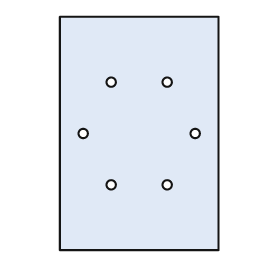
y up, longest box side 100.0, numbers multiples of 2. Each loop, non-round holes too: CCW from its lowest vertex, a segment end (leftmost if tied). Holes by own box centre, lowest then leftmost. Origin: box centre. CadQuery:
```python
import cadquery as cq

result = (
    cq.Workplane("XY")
    .moveTo(-34.0, -50.0)
    .lineTo(34.0, -50.0)
    .lineTo(34.0, 50.0)
    .lineTo(-34.0, 50.0)
    .close()
    .moveTo(-12.0, -22.0)
    .circle(2.0)
    .moveTo(12.0, -22.0)
    .circle(2.0)
    .moveTo(-24.0, 0.0)
    .circle(2.0)
    .moveTo(24.0, 0.0)
    .circle(2.0)
    .moveTo(-12.0, 22.0)
    .circle(2.0)
    .moveTo(12.0, 22.0)
    .circle(2.0)
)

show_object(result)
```